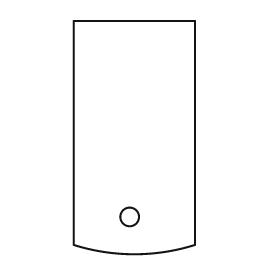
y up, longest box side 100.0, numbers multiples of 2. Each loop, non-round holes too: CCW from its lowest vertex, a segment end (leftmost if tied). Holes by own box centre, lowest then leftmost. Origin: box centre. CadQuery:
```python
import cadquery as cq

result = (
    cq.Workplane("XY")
    .moveTo(-26.0, -46.0)
    .threePointArc((0.0, -50.0), (26.0, -46.0))
    .lineTo(26.0, 50.0)
    .lineTo(-26.0, 50.0)
    .close()
    .moveTo(-2.0, -34.0)
    .circle(4.0)
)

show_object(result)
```